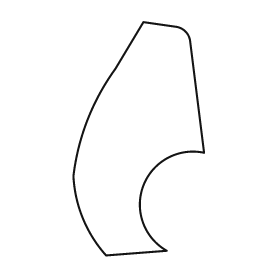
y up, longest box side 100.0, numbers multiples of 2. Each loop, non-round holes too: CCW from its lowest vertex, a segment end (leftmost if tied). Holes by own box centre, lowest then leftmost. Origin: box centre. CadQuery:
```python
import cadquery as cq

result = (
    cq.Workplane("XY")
    .moveTo(-14.0, -50.0)
    .lineTo(12.0, -48.0)
    .threePointArc((2.0, -20.0), (28.0, -6.0))
    .lineTo(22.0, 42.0)
    .threePointArc((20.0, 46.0), (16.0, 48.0))
    .lineTo(2.0, 50.0)
    .lineTo(-10.0, 30.0)
    .threePointArc((-22.0, 8.0), (-28.0, -16.0))
    .threePointArc((-24.0, -34.0), (-14.0, -50.0))
    .close()
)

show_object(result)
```